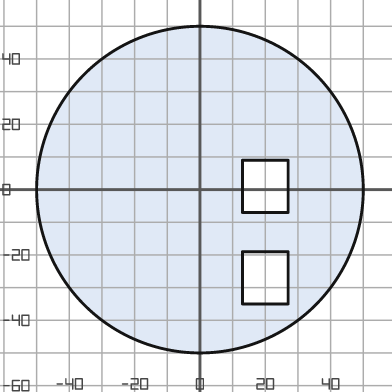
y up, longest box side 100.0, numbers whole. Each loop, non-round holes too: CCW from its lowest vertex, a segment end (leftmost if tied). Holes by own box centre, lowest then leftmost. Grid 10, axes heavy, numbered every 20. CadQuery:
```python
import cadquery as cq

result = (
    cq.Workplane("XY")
    .moveTo(0.0, 0.0)
    .circle(50.0)
    .moveTo(13.0, -35.0)
    .lineTo(27.0, -35.0)
    .lineTo(27.0, -19.0)
    .lineTo(13.0, -19.0)
    .close()
    .moveTo(13.0, -7.0)
    .lineTo(27.0, -7.0)
    .lineTo(27.0, 9.0)
    .lineTo(13.0, 9.0)
    .close()
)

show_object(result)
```